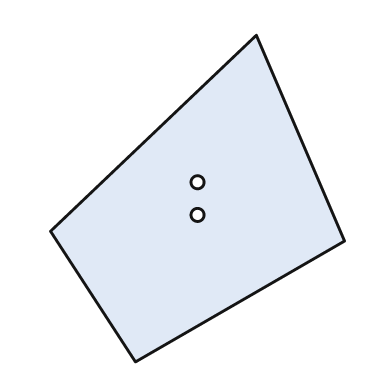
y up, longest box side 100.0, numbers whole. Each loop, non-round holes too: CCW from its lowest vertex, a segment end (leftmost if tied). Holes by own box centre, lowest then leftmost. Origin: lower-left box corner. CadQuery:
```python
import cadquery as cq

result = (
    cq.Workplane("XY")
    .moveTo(26.0, 0.0)
    .lineTo(90.0, 37.0)
    .lineTo(63.0, 100.0)
    .lineTo(0.0, 40.0)
    .close()
    .moveTo(45.0, 45.0)
    .circle(2.0)
    .moveTo(45.0, 55.0)
    .circle(2.0)
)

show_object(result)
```